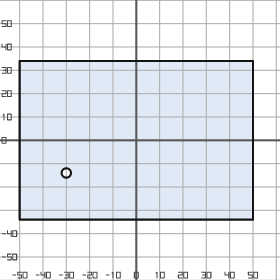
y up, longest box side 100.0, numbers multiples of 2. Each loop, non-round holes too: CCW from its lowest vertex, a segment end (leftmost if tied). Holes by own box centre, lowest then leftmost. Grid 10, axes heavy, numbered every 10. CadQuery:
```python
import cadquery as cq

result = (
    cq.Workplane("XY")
    .moveTo(-50.0, -34.0)
    .lineTo(50.0, -34.0)
    .lineTo(50.0, 34.0)
    .lineTo(-50.0, 34.0)
    .close()
    .moveTo(-30.0, -14.0)
    .circle(2.0)
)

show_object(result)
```